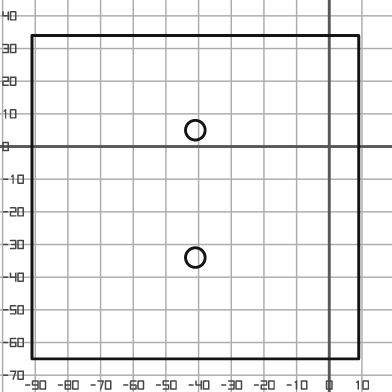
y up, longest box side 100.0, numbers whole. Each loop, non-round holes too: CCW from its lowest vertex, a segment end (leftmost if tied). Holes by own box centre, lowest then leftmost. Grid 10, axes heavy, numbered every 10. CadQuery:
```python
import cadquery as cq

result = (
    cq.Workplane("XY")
    .moveTo(-91.0, -65.0)
    .lineTo(9.0, -65.0)
    .lineTo(9.0, 34.0)
    .lineTo(-91.0, 34.0)
    .close()
    .moveTo(-41.0, -34.0)
    .circle(3.0)
    .moveTo(-41.0, 5.0)
    .circle(3.0)
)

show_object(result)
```